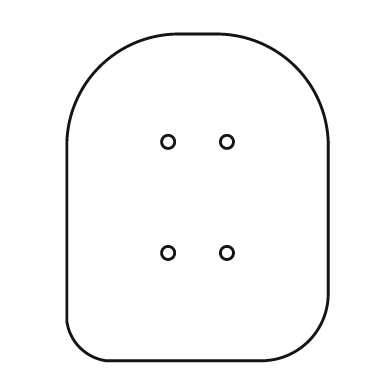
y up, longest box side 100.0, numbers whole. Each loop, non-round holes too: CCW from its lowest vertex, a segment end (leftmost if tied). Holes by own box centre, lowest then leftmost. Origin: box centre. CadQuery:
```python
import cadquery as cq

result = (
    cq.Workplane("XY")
    .moveTo(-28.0, -50.0)
    .lineTo(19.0, -50.0)
    .threePointArc((34.0, -44.0), (40.0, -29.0))
    .lineTo(40.0, 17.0)
    .threePointArc((30.0, 40.0), (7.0, 50.0))
    .lineTo(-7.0, 50.0)
    .threePointArc((-30.0, 40.0), (-40.0, 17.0))
    .lineTo(-40.0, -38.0)
    .threePointArc((-36.0, -46.0), (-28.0, -50.0))
    .close()
    .moveTo(-9.0, -17.0)
    .circle(2.0)
    .moveTo(9.0, -17.0)
    .circle(2.0)
    .moveTo(-9.0, 17.0)
    .circle(2.0)
    .moveTo(9.0, 17.0)
    .circle(2.0)
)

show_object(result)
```